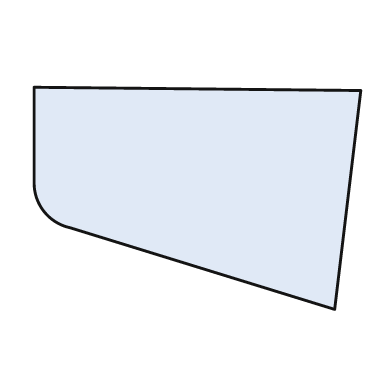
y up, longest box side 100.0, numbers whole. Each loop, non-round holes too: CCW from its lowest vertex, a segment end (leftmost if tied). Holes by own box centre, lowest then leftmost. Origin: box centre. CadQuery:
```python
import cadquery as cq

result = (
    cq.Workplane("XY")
    .moveTo(42.0, -34.0)
    .lineTo(50.0, 33.0)
    .lineTo(-50.0, 34.0)
    .lineTo(-50.0, 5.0)
    .threePointArc((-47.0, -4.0), (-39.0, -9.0))
    .close()
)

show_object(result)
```